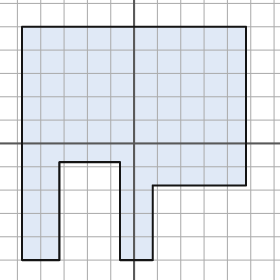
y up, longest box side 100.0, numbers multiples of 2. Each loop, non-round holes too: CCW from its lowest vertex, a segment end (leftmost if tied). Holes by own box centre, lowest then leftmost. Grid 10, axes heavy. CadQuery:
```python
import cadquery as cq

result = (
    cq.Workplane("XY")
    .moveTo(-48.0, -50.0)
    .lineTo(-32.0, -50.0)
    .lineTo(-32.0, -8.0)
    .lineTo(-6.0, -8.0)
    .lineTo(-6.0, -50.0)
    .lineTo(8.0, -50.0)
    .lineTo(8.0, -18.0)
    .lineTo(48.0, -18.0)
    .lineTo(48.0, 50.0)
    .lineTo(-48.0, 50.0)
    .close()
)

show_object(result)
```